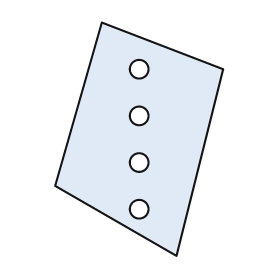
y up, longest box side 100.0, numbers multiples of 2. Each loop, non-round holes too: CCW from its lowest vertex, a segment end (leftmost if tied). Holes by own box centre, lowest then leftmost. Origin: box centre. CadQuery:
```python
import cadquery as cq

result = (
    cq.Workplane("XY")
    .moveTo(16.0, -50.0)
    .lineTo(36.0, 30.0)
    .lineTo(-16.0, 50.0)
    .lineTo(-36.0, -20.0)
    .close()
    .moveTo(0.0, -30.0)
    .circle(4.0)
    .moveTo(0.0, -10.0)
    .circle(4.0)
    .moveTo(0.0, 10.0)
    .circle(4.0)
    .moveTo(0.0, 30.0)
    .circle(4.0)
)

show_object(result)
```